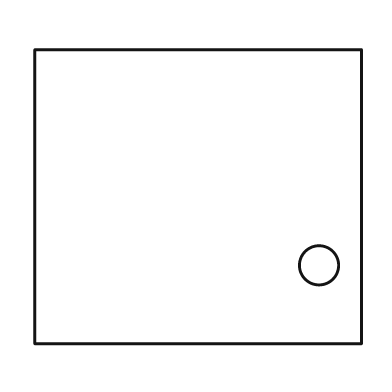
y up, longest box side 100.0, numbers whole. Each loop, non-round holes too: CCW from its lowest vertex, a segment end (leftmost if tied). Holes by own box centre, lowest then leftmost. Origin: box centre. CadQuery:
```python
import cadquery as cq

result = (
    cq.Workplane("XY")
    .moveTo(-50.0, -45.0)
    .lineTo(50.0, -45.0)
    .lineTo(50.0, 45.0)
    .lineTo(-50.0, 45.0)
    .close()
    .moveTo(37.0, -21.0)
    .circle(6.0)
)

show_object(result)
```